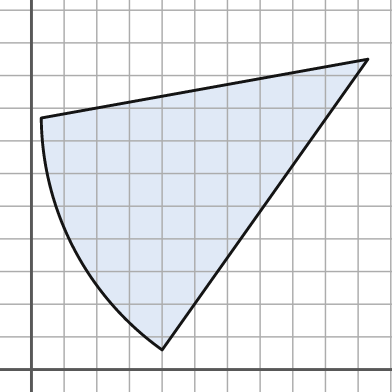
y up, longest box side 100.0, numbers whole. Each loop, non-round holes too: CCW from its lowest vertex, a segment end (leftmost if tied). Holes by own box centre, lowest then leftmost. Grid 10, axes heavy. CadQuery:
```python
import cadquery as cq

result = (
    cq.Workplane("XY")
    .moveTo(40.0, 6.0)
    .lineTo(103.0, 95.0)
    .lineTo(3.0, 77.0)
    .threePointArc((13.0, 37.0), (40.0, 6.0))
    .close()
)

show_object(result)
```